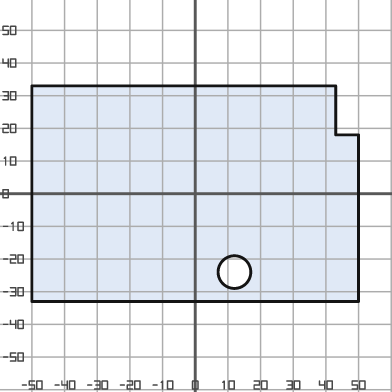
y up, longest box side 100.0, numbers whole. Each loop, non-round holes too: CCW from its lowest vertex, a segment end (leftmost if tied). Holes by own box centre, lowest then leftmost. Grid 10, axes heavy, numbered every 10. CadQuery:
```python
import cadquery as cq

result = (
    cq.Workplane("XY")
    .moveTo(-50.0, -33.0)
    .lineTo(50.0, -33.0)
    .lineTo(50.0, 18.0)
    .lineTo(43.0, 18.0)
    .lineTo(43.0, 33.0)
    .lineTo(-50.0, 33.0)
    .close()
    .moveTo(12.0, -24.0)
    .circle(5.0)
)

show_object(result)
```